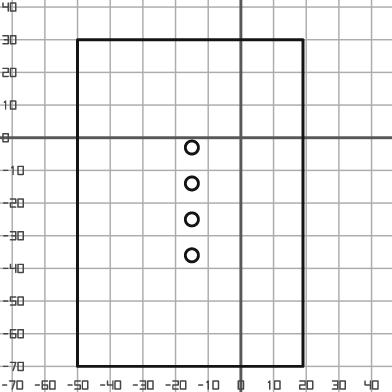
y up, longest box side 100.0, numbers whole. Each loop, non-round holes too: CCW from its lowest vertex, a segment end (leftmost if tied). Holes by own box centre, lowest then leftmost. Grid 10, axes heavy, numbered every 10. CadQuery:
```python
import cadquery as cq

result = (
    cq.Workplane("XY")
    .moveTo(-50.0, -70.0)
    .lineTo(19.0, -70.0)
    .lineTo(19.0, 30.0)
    .lineTo(-50.0, 30.0)
    .close()
    .moveTo(-15.0, -36.0)
    .circle(2.0)
    .moveTo(-15.0, -25.0)
    .circle(2.0)
    .moveTo(-15.0, -14.0)
    .circle(2.0)
    .moveTo(-15.0, -3.0)
    .circle(2.0)
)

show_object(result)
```